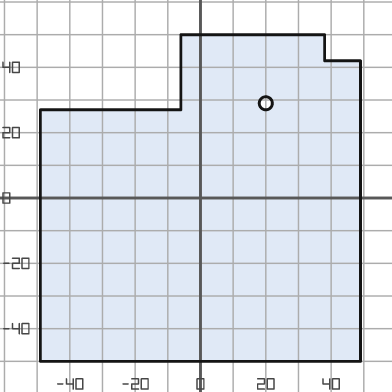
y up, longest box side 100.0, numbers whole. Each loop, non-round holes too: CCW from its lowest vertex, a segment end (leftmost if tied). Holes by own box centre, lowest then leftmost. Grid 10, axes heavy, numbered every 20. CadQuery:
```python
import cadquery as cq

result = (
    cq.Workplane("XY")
    .moveTo(-49.0, -50.0)
    .lineTo(49.0, -50.0)
    .lineTo(49.0, 42.0)
    .lineTo(38.0, 42.0)
    .lineTo(38.0, 50.0)
    .lineTo(-6.0, 50.0)
    .lineTo(-6.0, 27.0)
    .lineTo(-49.0, 27.0)
    .close()
    .moveTo(20.0, 29.0)
    .circle(2.0)
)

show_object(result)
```